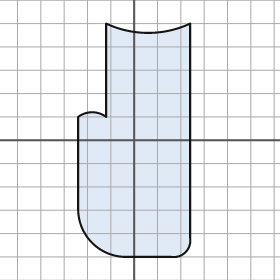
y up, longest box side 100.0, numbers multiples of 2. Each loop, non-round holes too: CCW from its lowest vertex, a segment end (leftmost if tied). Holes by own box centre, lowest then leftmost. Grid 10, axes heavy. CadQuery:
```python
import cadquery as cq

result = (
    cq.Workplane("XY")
    .moveTo(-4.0, -50.0)
    .lineTo(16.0, -50.0)
    .threePointArc((22.0, -48.0), (24.0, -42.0))
    .lineTo(24.0, 50.0)
    .threePointArc((6.0, 46.0), (-12.0, 50.0))
    .lineTo(-12.0, 10.0)
    .threePointArc((-18.0, 12.0), (-24.0, 10.0))
    .lineTo(-24.0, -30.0)
    .threePointArc((-18.0, -44.0), (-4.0, -50.0))
    .close()
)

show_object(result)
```